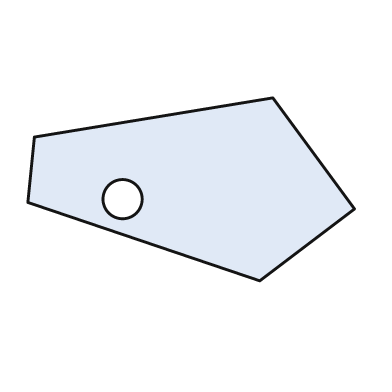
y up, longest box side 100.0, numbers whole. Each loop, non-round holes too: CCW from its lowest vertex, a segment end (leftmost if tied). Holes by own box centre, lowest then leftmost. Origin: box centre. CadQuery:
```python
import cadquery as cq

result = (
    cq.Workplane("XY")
    .moveTo(21.0, -28.0)
    .lineTo(50.0, -6.0)
    .lineTo(25.0, 28.0)
    .lineTo(-48.0, 16.0)
    .lineTo(-50.0, -4.0)
    .close()
    .moveTo(-21.0, -3.0)
    .circle(6.0)
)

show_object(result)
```